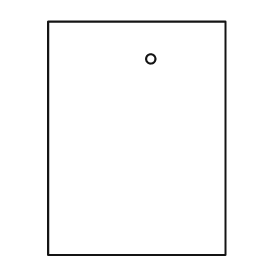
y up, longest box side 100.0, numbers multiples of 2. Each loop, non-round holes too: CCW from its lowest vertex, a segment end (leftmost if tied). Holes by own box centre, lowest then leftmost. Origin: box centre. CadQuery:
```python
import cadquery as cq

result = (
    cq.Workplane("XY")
    .moveTo(-38.0, -50.0)
    .lineTo(38.0, -50.0)
    .lineTo(38.0, 50.0)
    .lineTo(-38.0, 50.0)
    .close()
    .moveTo(6.0, 34.0)
    .circle(2.0)
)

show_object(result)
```